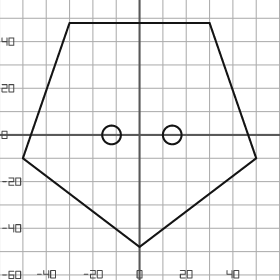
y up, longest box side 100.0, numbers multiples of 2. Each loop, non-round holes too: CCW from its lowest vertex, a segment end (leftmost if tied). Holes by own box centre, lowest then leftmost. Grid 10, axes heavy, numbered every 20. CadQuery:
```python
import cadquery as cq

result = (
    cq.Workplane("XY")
    .moveTo(0.0, -48.0)
    .lineTo(50.0, -10.0)
    .lineTo(30.0, 48.0)
    .lineTo(-30.0, 48.0)
    .lineTo(-50.0, -10.0)
    .close()
    .moveTo(-12.0, 0.0)
    .circle(4.0)
    .moveTo(14.0, 0.0)
    .circle(4.0)
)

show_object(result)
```